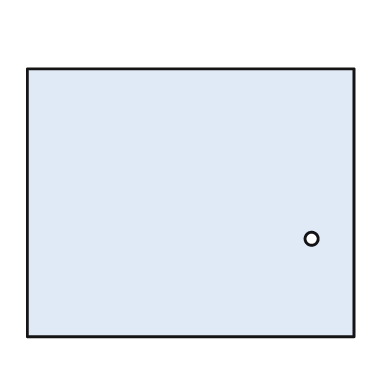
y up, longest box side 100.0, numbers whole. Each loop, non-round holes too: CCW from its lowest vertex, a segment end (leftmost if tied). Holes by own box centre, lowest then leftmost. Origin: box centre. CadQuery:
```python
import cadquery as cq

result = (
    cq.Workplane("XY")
    .moveTo(-50.0, -41.0)
    .lineTo(50.0, -41.0)
    .lineTo(50.0, 41.0)
    .lineTo(-50.0, 41.0)
    .close()
    .moveTo(37.0, -11.0)
    .circle(2.0)
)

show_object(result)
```